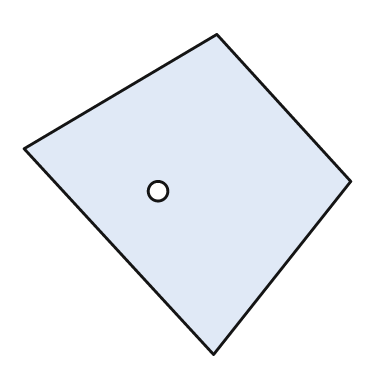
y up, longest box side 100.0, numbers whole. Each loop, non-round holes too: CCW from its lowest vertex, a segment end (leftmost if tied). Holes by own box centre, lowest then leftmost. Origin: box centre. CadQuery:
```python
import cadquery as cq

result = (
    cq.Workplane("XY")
    .moveTo(8.0, -49.0)
    .lineTo(50.0, 4.0)
    .lineTo(9.0, 49.0)
    .lineTo(-50.0, 14.0)
    .close()
    .moveTo(-9.0, 1.0)
    .circle(3.0)
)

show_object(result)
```